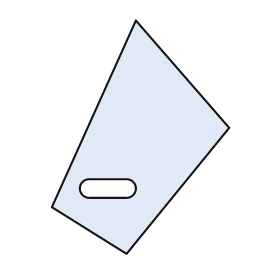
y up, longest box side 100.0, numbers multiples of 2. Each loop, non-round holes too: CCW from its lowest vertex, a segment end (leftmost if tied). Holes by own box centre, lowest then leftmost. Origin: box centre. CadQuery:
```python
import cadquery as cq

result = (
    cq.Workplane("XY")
    .moveTo(-6.0, -50.0)
    .lineTo(38.0, 4.0)
    .lineTo(-2.0, 50.0)
    .lineTo(-38.0, -30.0)
    .close()
    .moveTo(-22.0, -26.0)
    .lineTo(-6.0, -26.0)
    .threePointArc((-2.0, -22.0), (-6.0, -18.0))
    .lineTo(-22.0, -18.0)
    .threePointArc((-26.0, -22.0), (-22.0, -26.0))
    .close()
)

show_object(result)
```